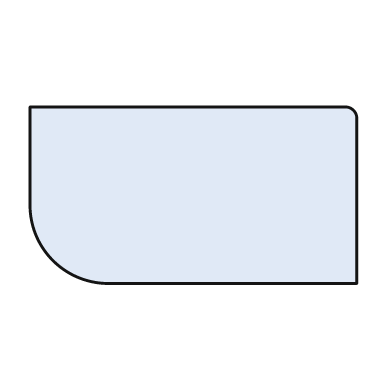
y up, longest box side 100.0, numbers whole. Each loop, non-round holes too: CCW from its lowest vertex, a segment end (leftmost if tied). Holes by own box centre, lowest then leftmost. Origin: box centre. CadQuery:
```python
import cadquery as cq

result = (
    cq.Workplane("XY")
    .moveTo(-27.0, -27.0)
    .lineTo(50.0, -27.0)
    .lineTo(50.0, 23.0)
    .threePointArc((49.0, 26.0), (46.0, 27.0))
    .lineTo(-50.0, 27.0)
    .lineTo(-50.0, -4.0)
    .threePointArc((-43.0, -20.0), (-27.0, -27.0))
    .close()
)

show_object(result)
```